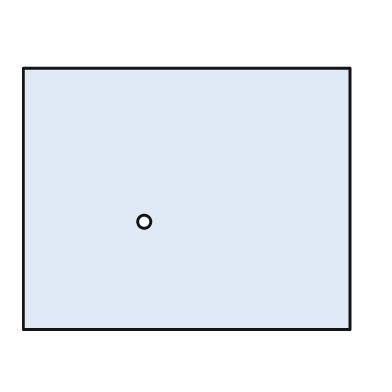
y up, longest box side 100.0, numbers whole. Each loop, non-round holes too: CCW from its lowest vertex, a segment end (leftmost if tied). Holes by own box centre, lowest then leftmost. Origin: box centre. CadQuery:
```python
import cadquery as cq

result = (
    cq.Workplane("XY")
    .moveTo(-50.0, -40.0)
    .lineTo(50.0, -40.0)
    .lineTo(50.0, 40.0)
    .lineTo(-50.0, 40.0)
    .close()
    .moveTo(-13.0, -7.0)
    .circle(2.0)
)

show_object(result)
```